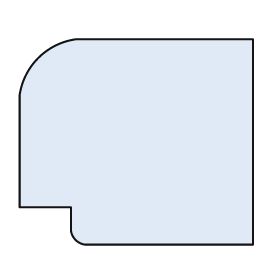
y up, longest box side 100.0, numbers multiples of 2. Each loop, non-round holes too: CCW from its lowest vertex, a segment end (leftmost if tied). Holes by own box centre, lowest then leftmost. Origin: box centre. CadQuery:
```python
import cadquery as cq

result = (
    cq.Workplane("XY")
    .moveTo(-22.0, -44.0)
    .lineTo(50.0, -44.0)
    .lineTo(50.0, 44.0)
    .lineTo(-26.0, 44.0)
    .threePointArc((-42.0, 36.0), (-50.0, 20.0))
    .lineTo(-50.0, -28.0)
    .lineTo(-28.0, -28.0)
    .lineTo(-28.0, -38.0)
    .threePointArc((-26.0, -42.0), (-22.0, -44.0))
    .close()
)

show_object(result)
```